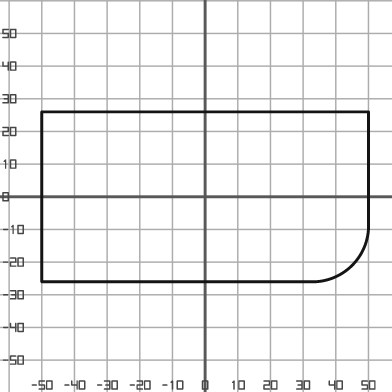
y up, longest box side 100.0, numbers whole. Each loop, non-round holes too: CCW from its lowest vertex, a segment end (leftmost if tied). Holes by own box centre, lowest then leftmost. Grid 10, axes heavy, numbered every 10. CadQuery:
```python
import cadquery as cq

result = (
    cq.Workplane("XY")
    .moveTo(-50.0, -26.0)
    .lineTo(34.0, -26.0)
    .threePointArc((45.0, -21.0), (50.0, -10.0))
    .lineTo(50.0, 26.0)
    .lineTo(-50.0, 26.0)
    .close()
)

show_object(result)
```